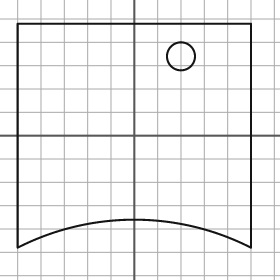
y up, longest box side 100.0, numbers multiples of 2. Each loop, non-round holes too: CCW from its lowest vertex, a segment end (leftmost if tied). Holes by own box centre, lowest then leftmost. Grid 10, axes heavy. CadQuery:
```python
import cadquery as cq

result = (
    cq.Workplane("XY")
    .moveTo(-50.0, -48.0)
    .threePointArc((0.0, -36.0), (50.0, -48.0))
    .lineTo(50.0, 48.0)
    .lineTo(-50.0, 48.0)
    .close()
    .moveTo(20.0, 34.0)
    .circle(6.0)
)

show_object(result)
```